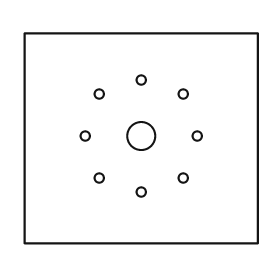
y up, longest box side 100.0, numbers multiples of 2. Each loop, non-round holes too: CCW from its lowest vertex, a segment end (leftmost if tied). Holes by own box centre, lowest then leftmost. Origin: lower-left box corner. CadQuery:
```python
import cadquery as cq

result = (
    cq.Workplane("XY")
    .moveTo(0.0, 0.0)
    .lineTo(100.0, 0.0)
    .lineTo(100.0, 90.0)
    .lineTo(0.0, 90.0)
    .close()
    .moveTo(50.0, 22.0)
    .circle(2.0)
    .moveTo(32.0, 28.0)
    .circle(2.0)
    .moveTo(68.0, 28.0)
    .circle(2.0)
    .moveTo(26.0, 46.0)
    .circle(2.0)
    .moveTo(50.0, 46.0)
    .circle(6.0)
    .moveTo(74.0, 46.0)
    .circle(2.0)
    .moveTo(32.0, 64.0)
    .circle(2.0)
    .moveTo(68.0, 64.0)
    .circle(2.0)
    .moveTo(50.0, 70.0)
    .circle(2.0)
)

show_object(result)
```